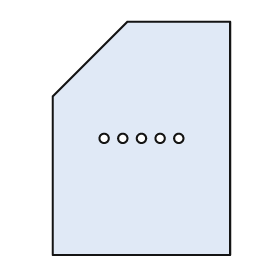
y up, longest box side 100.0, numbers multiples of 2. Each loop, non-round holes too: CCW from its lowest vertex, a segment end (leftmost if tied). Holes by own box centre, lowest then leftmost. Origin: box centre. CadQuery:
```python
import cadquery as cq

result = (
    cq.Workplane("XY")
    .moveTo(-38.0, -50.0)
    .lineTo(38.0, -50.0)
    .lineTo(38.0, 50.0)
    .lineTo(-6.0, 50.0)
    .lineTo(-38.0, 18.0)
    .close()
    .moveTo(-16.0, 0.0)
    .circle(2.0)
    .moveTo(-8.0, 0.0)
    .circle(2.0)
    .moveTo(0.0, 0.0)
    .circle(2.0)
    .moveTo(8.0, 0.0)
    .circle(2.0)
    .moveTo(16.0, 0.0)
    .circle(2.0)
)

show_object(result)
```